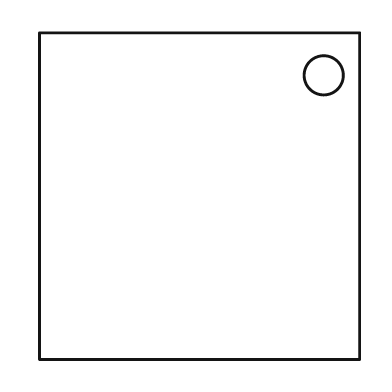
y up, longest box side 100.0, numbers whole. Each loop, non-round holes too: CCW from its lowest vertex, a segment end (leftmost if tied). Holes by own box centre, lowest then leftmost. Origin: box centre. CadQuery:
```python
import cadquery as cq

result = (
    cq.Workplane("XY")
    .moveTo(-49.0, -50.0)
    .lineTo(49.0, -50.0)
    .lineTo(49.0, 50.0)
    .lineTo(-49.0, 50.0)
    .close()
    .moveTo(38.0, 37.0)
    .circle(6.0)
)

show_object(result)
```